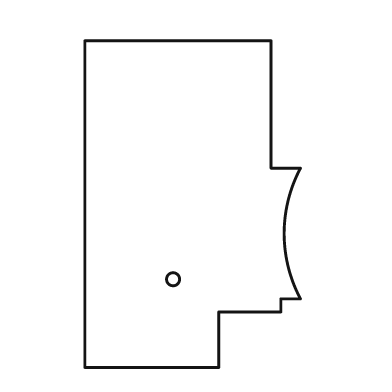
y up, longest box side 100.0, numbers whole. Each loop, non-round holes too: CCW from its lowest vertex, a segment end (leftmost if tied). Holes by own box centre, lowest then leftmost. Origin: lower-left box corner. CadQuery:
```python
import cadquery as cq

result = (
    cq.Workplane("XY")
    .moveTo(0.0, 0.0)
    .lineTo(41.0, 0.0)
    .lineTo(41.0, 17.0)
    .lineTo(60.0, 17.0)
    .lineTo(60.0, 21.0)
    .lineTo(66.0, 21.0)
    .threePointArc((61.0, 41.0), (66.0, 61.0))
    .lineTo(57.0, 61.0)
    .lineTo(57.0, 100.0)
    .lineTo(0.0, 100.0)
    .close()
    .moveTo(27.0, 27.0)
    .circle(2.0)
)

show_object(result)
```